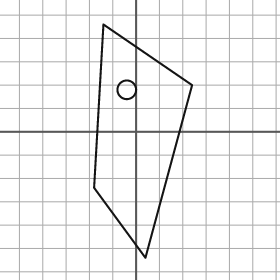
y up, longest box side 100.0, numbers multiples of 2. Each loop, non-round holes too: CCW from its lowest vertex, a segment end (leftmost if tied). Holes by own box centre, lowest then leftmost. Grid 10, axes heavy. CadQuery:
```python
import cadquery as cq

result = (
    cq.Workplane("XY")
    .moveTo(4.0, -54.0)
    .lineTo(24.0, 20.0)
    .lineTo(-14.0, 46.0)
    .lineTo(-18.0, -24.0)
    .close()
    .moveTo(-4.0, 18.0)
    .circle(4.0)
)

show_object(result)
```